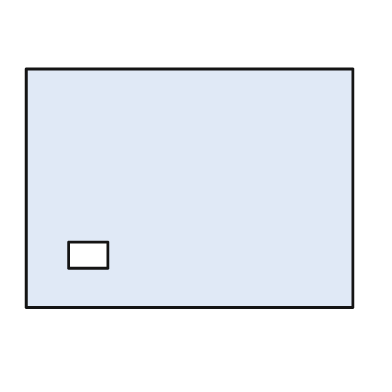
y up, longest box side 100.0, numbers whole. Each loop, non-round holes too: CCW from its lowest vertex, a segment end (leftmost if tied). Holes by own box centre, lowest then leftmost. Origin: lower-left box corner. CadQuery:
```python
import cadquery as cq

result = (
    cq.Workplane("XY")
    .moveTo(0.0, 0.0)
    .lineTo(100.0, 0.0)
    .lineTo(100.0, 73.0)
    .lineTo(0.0, 73.0)
    .close()
    .moveTo(13.0, 12.0)
    .lineTo(25.0, 12.0)
    .lineTo(25.0, 20.0)
    .lineTo(13.0, 20.0)
    .close()
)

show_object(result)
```